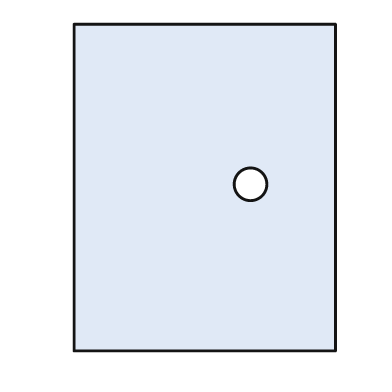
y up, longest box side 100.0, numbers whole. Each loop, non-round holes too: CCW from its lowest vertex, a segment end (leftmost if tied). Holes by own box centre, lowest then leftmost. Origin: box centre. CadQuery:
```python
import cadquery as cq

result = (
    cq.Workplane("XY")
    .moveTo(-40.0, -50.0)
    .lineTo(40.0, -50.0)
    .lineTo(40.0, 50.0)
    .lineTo(-40.0, 50.0)
    .close()
    .moveTo(14.0, 1.0)
    .circle(5.0)
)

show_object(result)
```